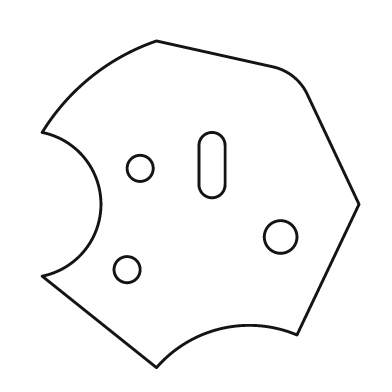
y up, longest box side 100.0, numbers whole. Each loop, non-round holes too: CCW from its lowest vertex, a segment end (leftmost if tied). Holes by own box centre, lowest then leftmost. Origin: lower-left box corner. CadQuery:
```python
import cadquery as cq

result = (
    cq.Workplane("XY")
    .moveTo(35.0, 0.0)
    .threePointArc((55.0, 12.0), (78.0, 10.0))
    .lineTo(97.0, 50.0)
    .lineTo(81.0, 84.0)
    .threePointArc((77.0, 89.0), (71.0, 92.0))
    .lineTo(35.0, 100.0)
    .threePointArc((15.0, 89.0), (0.0, 72.0))
    .threePointArc((18.0, 50.0), (0.0, 28.0))
    .close()
    .moveTo(26.0, 30.0)
    .circle(4.0)
    .moveTo(73.0, 40.0)
    .circle(5.0)
    .moveTo(30.0, 61.0)
    .circle(4.0)
    .moveTo(48.0, 56.0)
    .threePointArc((52.0, 52.0), (56.0, 56.0))
    .lineTo(56.0, 68.0)
    .threePointArc((52.0, 72.0), (48.0, 68.0))
    .close()
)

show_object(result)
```